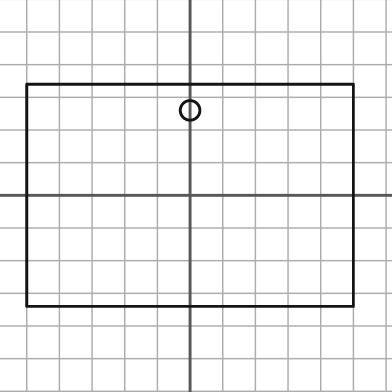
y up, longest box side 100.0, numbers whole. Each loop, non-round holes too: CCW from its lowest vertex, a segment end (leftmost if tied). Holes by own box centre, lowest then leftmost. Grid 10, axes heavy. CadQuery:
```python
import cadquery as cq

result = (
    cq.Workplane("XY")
    .moveTo(-50.0, -34.0)
    .lineTo(50.0, -34.0)
    .lineTo(50.0, 34.0)
    .lineTo(-50.0, 34.0)
    .close()
    .moveTo(0.0, 26.0)
    .circle(3.0)
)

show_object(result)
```